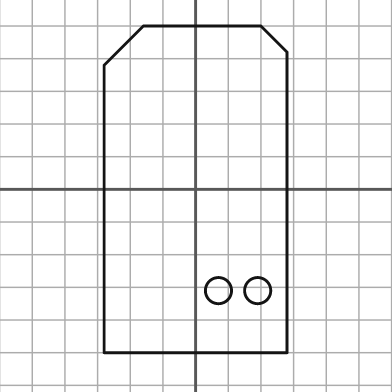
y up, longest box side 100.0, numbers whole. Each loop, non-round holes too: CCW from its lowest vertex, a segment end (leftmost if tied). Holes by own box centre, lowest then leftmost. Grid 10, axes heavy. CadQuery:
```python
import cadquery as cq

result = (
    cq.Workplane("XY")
    .moveTo(-28.0, -50.0)
    .lineTo(28.0, -50.0)
    .lineTo(28.0, 42.0)
    .lineTo(20.0, 50.0)
    .lineTo(-16.0, 50.0)
    .lineTo(-28.0, 38.0)
    .close()
    .moveTo(7.0, -31.0)
    .circle(4.0)
    .moveTo(19.0, -31.0)
    .circle(4.0)
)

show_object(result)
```